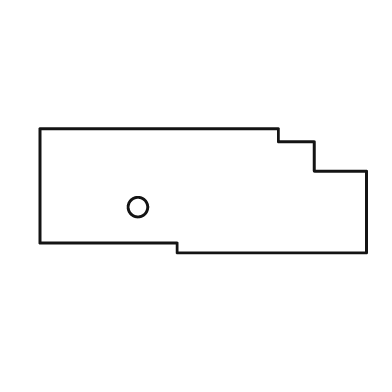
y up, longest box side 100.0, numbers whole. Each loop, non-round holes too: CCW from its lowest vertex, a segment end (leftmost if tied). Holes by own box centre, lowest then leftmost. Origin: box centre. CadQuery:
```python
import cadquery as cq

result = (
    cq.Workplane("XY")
    .moveTo(-8.0, -19.0)
    .lineTo(50.0, -19.0)
    .lineTo(50.0, 6.0)
    .lineTo(34.0, 6.0)
    .lineTo(34.0, 15.0)
    .lineTo(23.0, 15.0)
    .lineTo(23.0, 19.0)
    .lineTo(-50.0, 19.0)
    .lineTo(-50.0, -16.0)
    .lineTo(-8.0, -16.0)
    .close()
    .moveTo(-20.0, -5.0)
    .circle(3.0)
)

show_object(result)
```